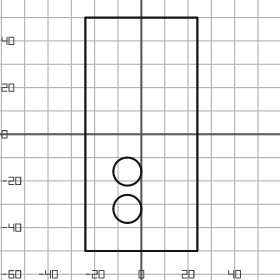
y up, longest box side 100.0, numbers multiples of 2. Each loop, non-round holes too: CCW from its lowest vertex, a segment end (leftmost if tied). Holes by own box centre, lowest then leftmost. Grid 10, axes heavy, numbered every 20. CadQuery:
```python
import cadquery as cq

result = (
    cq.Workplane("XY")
    .moveTo(-24.0, -50.0)
    .lineTo(24.0, -50.0)
    .lineTo(24.0, 50.0)
    .lineTo(-24.0, 50.0)
    .close()
    .moveTo(-6.0, -32.0)
    .circle(6.0)
    .moveTo(-6.0, -16.0)
    .circle(6.0)
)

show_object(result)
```